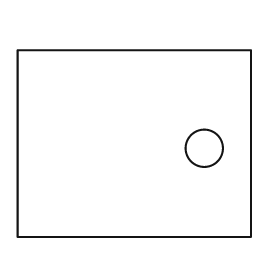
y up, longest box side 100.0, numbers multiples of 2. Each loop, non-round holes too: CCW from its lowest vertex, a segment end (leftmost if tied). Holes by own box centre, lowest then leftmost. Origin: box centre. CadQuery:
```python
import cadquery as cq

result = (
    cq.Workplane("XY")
    .moveTo(-50.0, -40.0)
    .lineTo(50.0, -40.0)
    .lineTo(50.0, 40.0)
    .lineTo(-50.0, 40.0)
    .close()
    .moveTo(30.0, -2.0)
    .circle(8.0)
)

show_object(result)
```